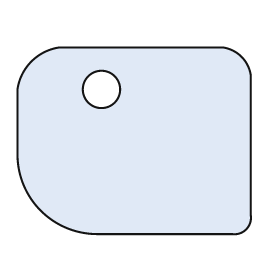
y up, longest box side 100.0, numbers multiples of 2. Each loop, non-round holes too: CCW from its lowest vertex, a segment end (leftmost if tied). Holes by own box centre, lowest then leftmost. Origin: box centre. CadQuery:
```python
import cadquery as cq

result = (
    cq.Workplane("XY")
    .moveTo(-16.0, -40.0)
    .lineTo(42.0, -40.0)
    .threePointArc((48.0, -38.0), (50.0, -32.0))
    .lineTo(50.0, 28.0)
    .threePointArc((46.0, 36.0), (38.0, 40.0))
    .lineTo(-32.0, 40.0)
    .threePointArc((-44.0, 34.0), (-50.0, 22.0))
    .lineTo(-50.0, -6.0)
    .threePointArc((-40.0, -30.0), (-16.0, -40.0))
    .close()
    .moveTo(-14.0, 22.0)
    .circle(8.0)
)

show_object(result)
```